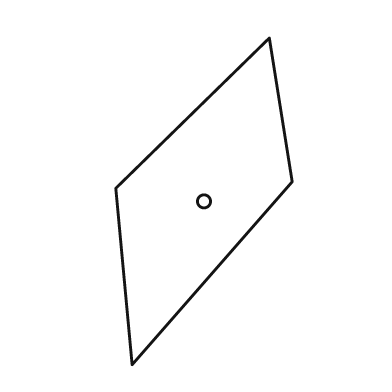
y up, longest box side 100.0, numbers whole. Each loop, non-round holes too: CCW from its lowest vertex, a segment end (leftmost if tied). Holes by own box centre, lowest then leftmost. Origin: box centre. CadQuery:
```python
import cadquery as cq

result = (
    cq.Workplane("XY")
    .moveTo(-22.0, -50.0)
    .lineTo(27.0, 6.0)
    .lineTo(20.0, 50.0)
    .lineTo(-27.0, 4.0)
    .close()
    .moveTo(0.0, 0.0)
    .circle(2.0)
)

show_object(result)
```